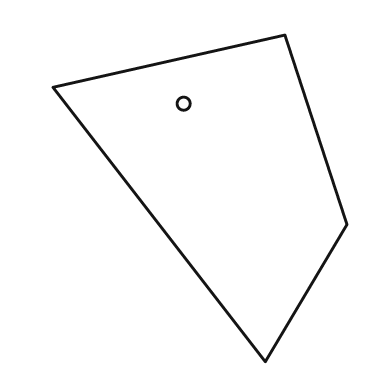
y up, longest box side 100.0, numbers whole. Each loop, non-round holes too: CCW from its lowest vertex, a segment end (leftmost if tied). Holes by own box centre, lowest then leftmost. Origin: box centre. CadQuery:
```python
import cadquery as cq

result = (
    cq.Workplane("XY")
    .moveTo(20.0, -50.0)
    .lineTo(45.0, -8.0)
    .lineTo(26.0, 50.0)
    .lineTo(-45.0, 34.0)
    .close()
    .moveTo(-5.0, 29.0)
    .circle(2.0)
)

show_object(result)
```